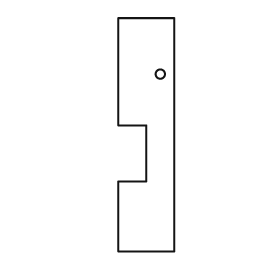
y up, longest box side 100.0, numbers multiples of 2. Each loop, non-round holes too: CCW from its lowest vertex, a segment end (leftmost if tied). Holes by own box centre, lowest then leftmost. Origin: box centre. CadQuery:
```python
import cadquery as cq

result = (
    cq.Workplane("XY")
    .moveTo(-12.0, -50.0)
    .lineTo(12.0, -50.0)
    .lineTo(12.0, 50.0)
    .lineTo(-12.0, 50.0)
    .lineTo(-12.0, 4.0)
    .lineTo(0.0, 4.0)
    .lineTo(0.0, -20.0)
    .lineTo(-12.0, -20.0)
    .close()
    .moveTo(6.0, 26.0)
    .circle(2.0)
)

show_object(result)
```